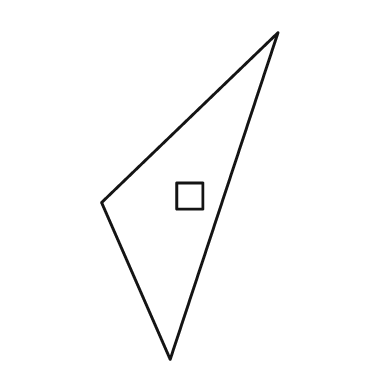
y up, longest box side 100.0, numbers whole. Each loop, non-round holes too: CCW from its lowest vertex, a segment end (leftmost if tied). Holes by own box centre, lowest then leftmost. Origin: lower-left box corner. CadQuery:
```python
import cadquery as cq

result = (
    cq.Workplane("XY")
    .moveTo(21.0, 0.0)
    .lineTo(54.0, 100.0)
    .lineTo(0.0, 48.0)
    .close()
    .moveTo(23.0, 46.0)
    .lineTo(31.0, 46.0)
    .lineTo(31.0, 54.0)
    .lineTo(23.0, 54.0)
    .close()
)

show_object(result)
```